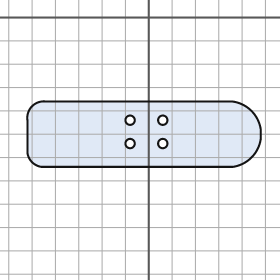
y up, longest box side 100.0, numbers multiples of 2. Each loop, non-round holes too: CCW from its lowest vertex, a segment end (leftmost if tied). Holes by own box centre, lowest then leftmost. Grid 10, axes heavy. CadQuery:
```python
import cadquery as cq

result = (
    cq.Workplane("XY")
    .moveTo(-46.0, -64.0)
    .lineTo(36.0, -64.0)
    .threePointArc((44.0, -60.0), (48.0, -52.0))
    .lineTo(48.0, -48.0)
    .threePointArc((44.0, -40.0), (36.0, -36.0))
    .lineTo(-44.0, -36.0)
    .threePointArc((-50.0, -38.0), (-52.0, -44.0))
    .lineTo(-52.0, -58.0)
    .threePointArc((-50.0, -62.0), (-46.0, -64.0))
    .close()
    .moveTo(-8.0, -54.0)
    .circle(2.0)
    .moveTo(6.0, -54.0)
    .circle(2.0)
    .moveTo(-8.0, -44.0)
    .circle(2.0)
    .moveTo(6.0, -44.0)
    .circle(2.0)
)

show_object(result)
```